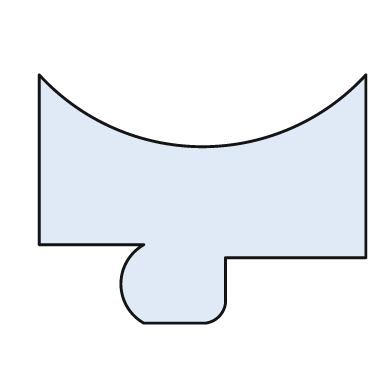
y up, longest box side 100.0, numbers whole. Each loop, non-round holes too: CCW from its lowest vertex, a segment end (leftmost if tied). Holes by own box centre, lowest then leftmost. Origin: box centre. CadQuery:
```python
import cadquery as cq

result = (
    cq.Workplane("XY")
    .moveTo(-18.0, -38.0)
    .lineTo(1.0, -38.0)
    .threePointArc((5.0, -36.0), (7.0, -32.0))
    .lineTo(7.0, -18.0)
    .lineTo(50.0, -18.0)
    .lineTo(50.0, 38.0)
    .threePointArc((0.0, 16.0), (-50.0, 38.0))
    .lineTo(-50.0, -14.0)
    .lineTo(-18.0, -14.0)
    .threePointArc((-25.0, -26.0), (-18.0, -38.0))
    .close()
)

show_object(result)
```